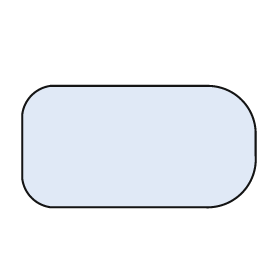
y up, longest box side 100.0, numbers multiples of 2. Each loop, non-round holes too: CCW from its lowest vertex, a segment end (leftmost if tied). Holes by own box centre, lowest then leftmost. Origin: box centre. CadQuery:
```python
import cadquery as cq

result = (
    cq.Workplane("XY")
    .moveTo(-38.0, -26.0)
    .lineTo(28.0, -26.0)
    .threePointArc((44.0, -20.0), (50.0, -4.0))
    .lineTo(50.0, 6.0)
    .threePointArc((44.0, 20.0), (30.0, 26.0))
    .lineTo(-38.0, 26.0)
    .threePointArc((-46.0, 22.0), (-50.0, 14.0))
    .lineTo(-50.0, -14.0)
    .threePointArc((-46.0, -22.0), (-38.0, -26.0))
    .close()
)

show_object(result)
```